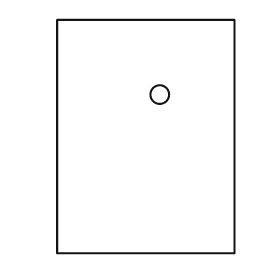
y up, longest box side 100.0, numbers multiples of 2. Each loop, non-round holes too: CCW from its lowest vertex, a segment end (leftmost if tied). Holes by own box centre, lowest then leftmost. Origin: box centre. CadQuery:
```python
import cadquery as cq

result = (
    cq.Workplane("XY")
    .moveTo(-38.0, -50.0)
    .lineTo(38.0, -50.0)
    .lineTo(38.0, 50.0)
    .lineTo(-38.0, 50.0)
    .close()
    .moveTo(6.0, 18.0)
    .circle(4.0)
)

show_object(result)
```